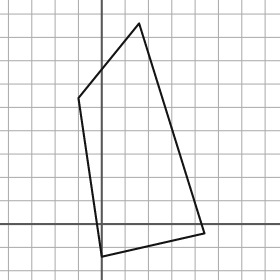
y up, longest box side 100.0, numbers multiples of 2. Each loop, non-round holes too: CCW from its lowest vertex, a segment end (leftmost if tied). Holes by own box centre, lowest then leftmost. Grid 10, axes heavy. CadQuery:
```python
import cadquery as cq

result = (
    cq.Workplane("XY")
    .moveTo(0.0, -14.0)
    .lineTo(44.0, -4.0)
    .lineTo(16.0, 86.0)
    .lineTo(-10.0, 54.0)
    .close()
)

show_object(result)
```